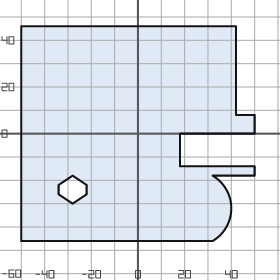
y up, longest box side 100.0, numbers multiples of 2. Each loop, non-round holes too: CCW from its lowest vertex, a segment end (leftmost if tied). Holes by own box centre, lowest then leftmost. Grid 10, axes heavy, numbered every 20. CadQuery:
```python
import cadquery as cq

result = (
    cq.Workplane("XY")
    .moveTo(-50.0, -46.0)
    .lineTo(32.0, -46.0)
    .threePointArc((40.0, -32.0), (32.0, -18.0))
    .lineTo(50.0, -18.0)
    .lineTo(50.0, -14.0)
    .lineTo(18.0, -14.0)
    .lineTo(18.0, 0.0)
    .lineTo(50.0, 0.0)
    .lineTo(50.0, 8.0)
    .lineTo(42.0, 8.0)
    .lineTo(42.0, 46.0)
    .lineTo(-50.0, 46.0)
    .close()
    .moveTo(-28.0, -30.0)
    .lineTo(-22.0, -26.0)
    .lineTo(-22.0, -22.0)
    .lineTo(-28.0, -18.0)
    .lineTo(-34.0, -22.0)
    .lineTo(-34.0, -26.0)
    .close()
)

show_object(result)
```